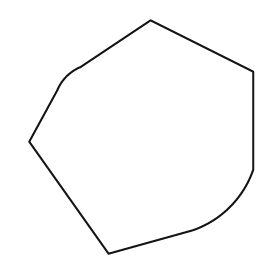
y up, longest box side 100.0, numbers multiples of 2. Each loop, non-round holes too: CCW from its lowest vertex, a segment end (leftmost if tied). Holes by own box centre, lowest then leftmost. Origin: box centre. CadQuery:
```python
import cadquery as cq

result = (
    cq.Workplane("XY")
    .moveTo(-14.0, -50.0)
    .lineTo(22.0, -40.0)
    .threePointArc((38.0, -30.0), (48.0, -14.0))
    .lineTo(48.0, 28.0)
    .lineTo(4.0, 50.0)
    .lineTo(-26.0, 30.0)
    .threePointArc((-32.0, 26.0), (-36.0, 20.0))
    .lineTo(-48.0, -2.0)
    .close()
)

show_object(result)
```